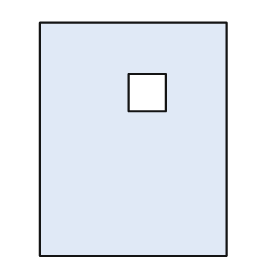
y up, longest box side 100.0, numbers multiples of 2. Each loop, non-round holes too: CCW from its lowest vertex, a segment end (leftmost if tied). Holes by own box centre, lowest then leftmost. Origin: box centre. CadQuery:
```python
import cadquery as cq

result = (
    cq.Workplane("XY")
    .moveTo(-40.0, -50.0)
    .lineTo(40.0, -50.0)
    .lineTo(40.0, 50.0)
    .lineTo(-40.0, 50.0)
    .close()
    .moveTo(-2.0, 12.0)
    .lineTo(14.0, 12.0)
    .lineTo(14.0, 28.0)
    .lineTo(-2.0, 28.0)
    .close()
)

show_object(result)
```